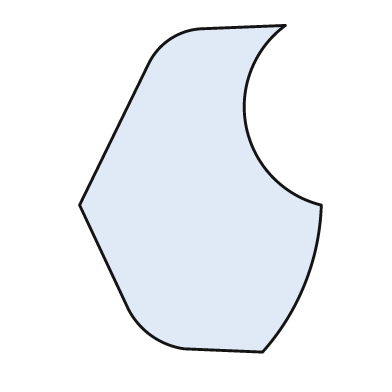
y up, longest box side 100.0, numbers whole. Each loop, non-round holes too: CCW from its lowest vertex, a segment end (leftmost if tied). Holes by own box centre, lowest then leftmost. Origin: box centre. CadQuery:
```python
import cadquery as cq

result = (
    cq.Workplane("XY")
    .moveTo(19.0, -50.0)
    .threePointArc((32.0, -29.0), (37.0, -5.0))
    .threePointArc((14.0, 19.0), (26.0, 50.0))
    .lineTo(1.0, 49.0)
    .threePointArc((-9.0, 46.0), (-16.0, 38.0))
    .lineTo(-37.0, -5.0)
    .lineTo(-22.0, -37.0)
    .threePointArc((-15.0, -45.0), (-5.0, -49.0))
    .close()
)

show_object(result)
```